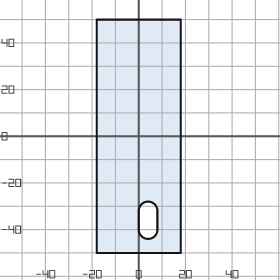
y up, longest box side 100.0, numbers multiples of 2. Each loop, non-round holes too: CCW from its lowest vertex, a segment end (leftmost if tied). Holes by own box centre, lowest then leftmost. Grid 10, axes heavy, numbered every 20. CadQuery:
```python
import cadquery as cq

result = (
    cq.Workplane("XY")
    .moveTo(-18.0, -50.0)
    .lineTo(18.0, -50.0)
    .lineTo(18.0, 50.0)
    .lineTo(-18.0, 50.0)
    .close()
    .moveTo(0.0, -40.0)
    .threePointArc((4.0, -44.0), (8.0, -40.0))
    .lineTo(8.0, -32.0)
    .threePointArc((4.0, -28.0), (0.0, -32.0))
    .close()
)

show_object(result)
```